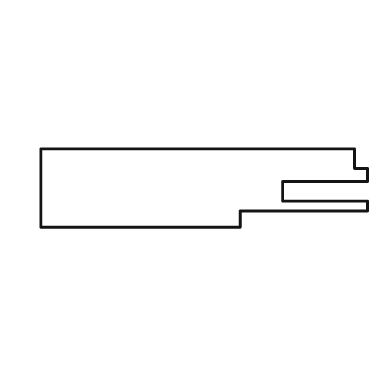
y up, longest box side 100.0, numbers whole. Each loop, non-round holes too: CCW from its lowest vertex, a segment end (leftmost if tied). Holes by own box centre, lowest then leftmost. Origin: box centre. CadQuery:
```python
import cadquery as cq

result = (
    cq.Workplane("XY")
    .moveTo(-50.0, -12.0)
    .lineTo(11.0, -12.0)
    .lineTo(11.0, -7.0)
    .lineTo(50.0, -7.0)
    .lineTo(50.0, -4.0)
    .lineTo(24.0, -4.0)
    .lineTo(24.0, 2.0)
    .lineTo(50.0, 2.0)
    .lineTo(50.0, 6.0)
    .lineTo(46.0, 6.0)
    .lineTo(46.0, 12.0)
    .lineTo(-50.0, 12.0)
    .close()
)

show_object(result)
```